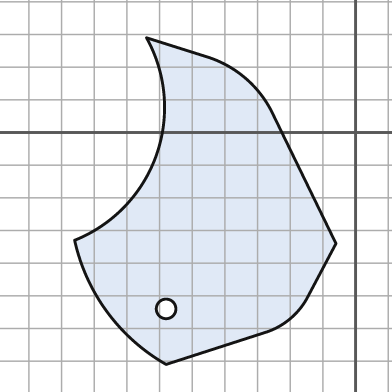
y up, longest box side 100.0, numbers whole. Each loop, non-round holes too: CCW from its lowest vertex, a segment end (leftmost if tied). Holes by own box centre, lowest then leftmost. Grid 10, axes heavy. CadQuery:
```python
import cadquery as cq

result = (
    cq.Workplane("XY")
    .moveTo(-58.0, -71.0)
    .lineTo(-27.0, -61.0)
    .threePointArc((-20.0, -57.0), (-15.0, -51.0))
    .lineTo(-6.0, -34.0)
    .lineTo(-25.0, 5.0)
    .threePointArc((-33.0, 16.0), (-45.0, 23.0))
    .lineTo(-64.0, 29.0)
    .threePointArc((-61.0, -7.0), (-86.0, -33.0))
    .threePointArc((-76.0, -55.0), (-58.0, -71.0))
    .close()
    .moveTo(-58.0, -54.0)
    .circle(3.0)
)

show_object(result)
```